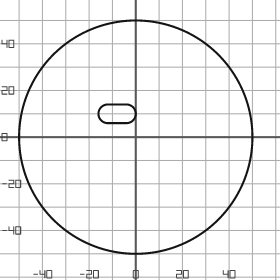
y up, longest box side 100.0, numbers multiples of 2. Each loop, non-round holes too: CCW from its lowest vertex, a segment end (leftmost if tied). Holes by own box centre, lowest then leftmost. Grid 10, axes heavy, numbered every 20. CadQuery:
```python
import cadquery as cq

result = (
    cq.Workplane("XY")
    .moveTo(0.0, 0.0)
    .circle(50.0)
    .moveTo(-12.0, 6.0)
    .lineTo(-4.0, 6.0)
    .threePointArc((0.0, 10.0), (-4.0, 14.0))
    .lineTo(-12.0, 14.0)
    .threePointArc((-16.0, 10.0), (-12.0, 6.0))
    .close()
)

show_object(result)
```